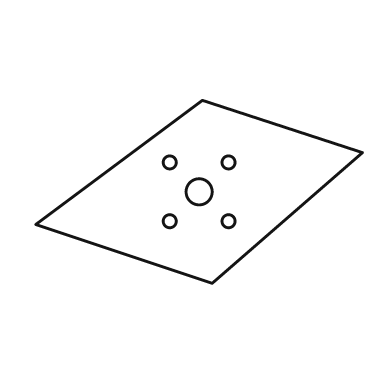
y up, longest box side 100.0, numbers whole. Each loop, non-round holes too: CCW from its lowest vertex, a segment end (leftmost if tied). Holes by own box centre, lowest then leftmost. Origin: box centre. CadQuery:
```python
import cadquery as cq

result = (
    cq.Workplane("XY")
    .moveTo(4.0, -28.0)
    .lineTo(50.0, 12.0)
    .lineTo(1.0, 28.0)
    .lineTo(-50.0, -10.0)
    .close()
    .moveTo(-9.0, -9.0)
    .circle(2.0)
    .moveTo(9.0, -9.0)
    .circle(2.0)
    .moveTo(0.0, 0.0)
    .circle(4.0)
    .moveTo(-9.0, 9.0)
    .circle(2.0)
    .moveTo(9.0, 9.0)
    .circle(2.0)
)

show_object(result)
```